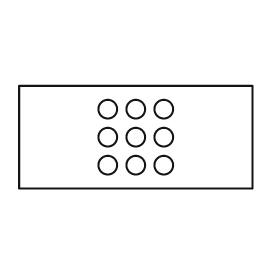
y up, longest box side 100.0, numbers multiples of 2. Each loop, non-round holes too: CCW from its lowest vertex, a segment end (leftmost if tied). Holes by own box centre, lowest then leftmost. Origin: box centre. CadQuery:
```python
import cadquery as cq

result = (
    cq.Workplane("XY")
    .moveTo(-50.0, -22.0)
    .lineTo(50.0, -22.0)
    .lineTo(50.0, 22.0)
    .lineTo(-50.0, 22.0)
    .close()
    .moveTo(-12.0, -12.0)
    .circle(4.0)
    .moveTo(0.0, -12.0)
    .circle(4.0)
    .moveTo(12.0, -12.0)
    .circle(4.0)
    .moveTo(-12.0, 0.0)
    .circle(4.0)
    .moveTo(0.0, 0.0)
    .circle(4.0)
    .moveTo(12.0, 0.0)
    .circle(4.0)
    .moveTo(-12.0, 12.0)
    .circle(4.0)
    .moveTo(0.0, 12.0)
    .circle(4.0)
    .moveTo(12.0, 12.0)
    .circle(4.0)
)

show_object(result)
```